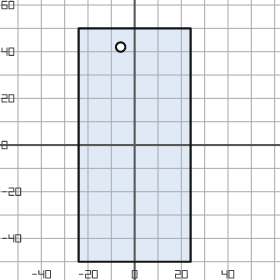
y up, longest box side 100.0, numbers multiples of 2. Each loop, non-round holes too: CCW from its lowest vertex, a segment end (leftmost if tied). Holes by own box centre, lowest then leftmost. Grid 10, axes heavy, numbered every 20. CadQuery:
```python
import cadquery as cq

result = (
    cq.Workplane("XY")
    .moveTo(-24.0, -50.0)
    .lineTo(24.0, -50.0)
    .lineTo(24.0, 50.0)
    .lineTo(-24.0, 50.0)
    .close()
    .moveTo(-6.0, 42.0)
    .circle(2.0)
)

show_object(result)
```